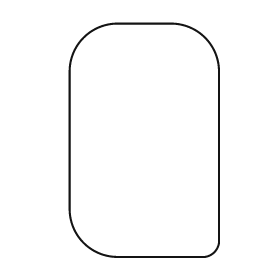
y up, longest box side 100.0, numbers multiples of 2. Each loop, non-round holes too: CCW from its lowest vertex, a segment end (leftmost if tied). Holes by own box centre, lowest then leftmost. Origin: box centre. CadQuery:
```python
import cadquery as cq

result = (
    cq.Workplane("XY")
    .moveTo(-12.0, -50.0)
    .lineTo(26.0, -50.0)
    .threePointArc((30.0, -48.0), (32.0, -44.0))
    .lineTo(32.0, 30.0)
    .threePointArc((26.0, 44.0), (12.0, 50.0))
    .lineTo(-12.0, 50.0)
    .threePointArc((-26.0, 44.0), (-32.0, 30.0))
    .lineTo(-32.0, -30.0)
    .threePointArc((-26.0, -44.0), (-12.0, -50.0))
    .close()
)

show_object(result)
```